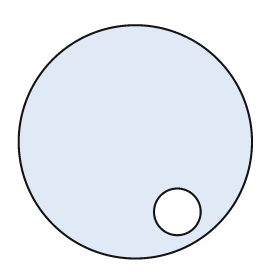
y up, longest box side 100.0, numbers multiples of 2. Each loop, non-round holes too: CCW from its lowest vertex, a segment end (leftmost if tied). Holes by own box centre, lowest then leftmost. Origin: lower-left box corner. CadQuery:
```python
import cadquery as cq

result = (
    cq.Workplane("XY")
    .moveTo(50.0, 50.0)
    .circle(50.0)
    .moveTo(68.0, 20.0)
    .circle(10.0)
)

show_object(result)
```